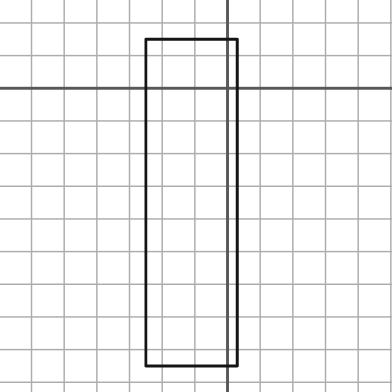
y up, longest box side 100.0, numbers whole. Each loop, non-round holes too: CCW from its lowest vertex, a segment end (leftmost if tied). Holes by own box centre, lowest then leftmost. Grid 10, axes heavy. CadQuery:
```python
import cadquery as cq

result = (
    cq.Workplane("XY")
    .moveTo(-25.0, -85.0)
    .lineTo(3.0, -85.0)
    .lineTo(3.0, 15.0)
    .lineTo(-25.0, 15.0)
    .close()
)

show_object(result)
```